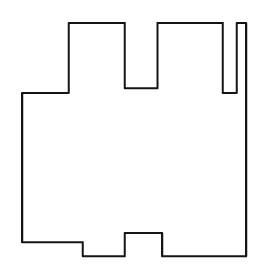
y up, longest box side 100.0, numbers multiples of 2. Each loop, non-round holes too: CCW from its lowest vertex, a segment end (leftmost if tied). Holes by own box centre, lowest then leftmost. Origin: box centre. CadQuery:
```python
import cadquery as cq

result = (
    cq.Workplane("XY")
    .moveTo(-22.0, -50.0)
    .lineTo(-4.0, -50.0)
    .lineTo(-4.0, -40.0)
    .lineTo(12.0, -40.0)
    .lineTo(12.0, -50.0)
    .lineTo(48.0, -50.0)
    .lineTo(48.0, 50.0)
    .lineTo(44.0, 50.0)
    .lineTo(44.0, 20.0)
    .lineTo(38.0, 20.0)
    .lineTo(38.0, 50.0)
    .lineTo(10.0, 50.0)
    .lineTo(10.0, 22.0)
    .lineTo(-4.0, 22.0)
    .lineTo(-4.0, 50.0)
    .lineTo(-28.0, 50.0)
    .lineTo(-28.0, 20.0)
    .lineTo(-48.0, 20.0)
    .lineTo(-48.0, -44.0)
    .lineTo(-22.0, -44.0)
    .close()
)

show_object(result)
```